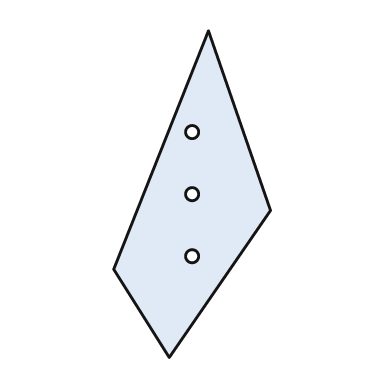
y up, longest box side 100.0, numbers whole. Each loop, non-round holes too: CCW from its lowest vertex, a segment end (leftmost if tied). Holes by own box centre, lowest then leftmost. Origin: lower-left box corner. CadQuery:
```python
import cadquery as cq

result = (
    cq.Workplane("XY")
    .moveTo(17.0, 0.0)
    .lineTo(48.0, 45.0)
    .lineTo(29.0, 100.0)
    .lineTo(0.0, 27.0)
    .close()
    .moveTo(24.0, 31.0)
    .circle(2.0)
    .moveTo(24.0, 50.0)
    .circle(2.0)
    .moveTo(24.0, 69.0)
    .circle(2.0)
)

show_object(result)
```